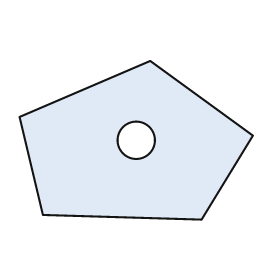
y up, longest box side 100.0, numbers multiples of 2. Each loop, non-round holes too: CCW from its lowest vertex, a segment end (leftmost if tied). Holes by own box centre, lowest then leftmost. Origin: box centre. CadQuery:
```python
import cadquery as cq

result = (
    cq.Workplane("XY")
    .moveTo(28.0, -34.0)
    .lineTo(50.0, 2.0)
    .lineTo(6.0, 34.0)
    .lineTo(-50.0, 10.0)
    .lineTo(-40.0, -32.0)
    .close()
    .moveTo(0.0, 0.0)
    .circle(8.0)
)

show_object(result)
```